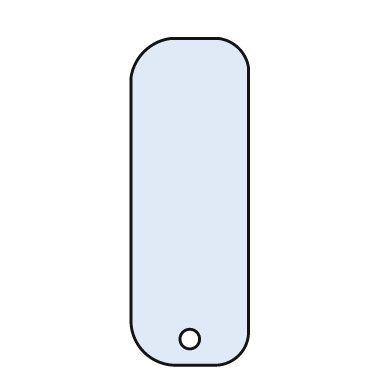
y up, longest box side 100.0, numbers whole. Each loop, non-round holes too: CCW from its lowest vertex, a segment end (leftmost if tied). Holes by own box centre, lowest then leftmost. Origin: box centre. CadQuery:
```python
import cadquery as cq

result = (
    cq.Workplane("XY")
    .moveTo(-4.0, -50.0)
    .lineTo(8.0, -50.0)
    .threePointArc((15.0, -47.0), (18.0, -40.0))
    .lineTo(18.0, 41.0)
    .threePointArc((15.0, 47.0), (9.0, 50.0))
    .lineTo(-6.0, 50.0)
    .threePointArc((-14.0, 46.0), (-18.0, 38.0))
    .lineTo(-18.0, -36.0)
    .threePointArc((-14.0, -46.0), (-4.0, -50.0))
    .close()
    .moveTo(0.0, -42.0)
    .circle(3.0)
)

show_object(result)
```